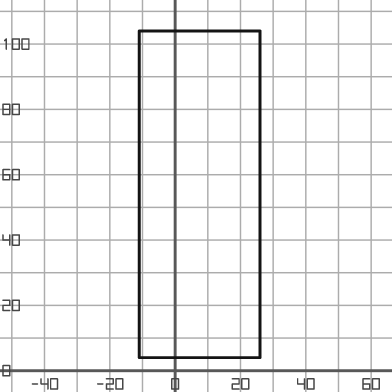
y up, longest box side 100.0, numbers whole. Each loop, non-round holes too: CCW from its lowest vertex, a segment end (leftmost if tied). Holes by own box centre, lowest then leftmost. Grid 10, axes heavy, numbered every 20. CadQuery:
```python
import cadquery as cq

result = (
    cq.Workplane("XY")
    .moveTo(-11.0, 4.0)
    .lineTo(26.0, 4.0)
    .lineTo(26.0, 104.0)
    .lineTo(-11.0, 104.0)
    .close()
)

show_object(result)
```